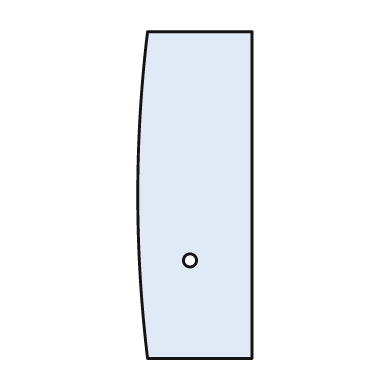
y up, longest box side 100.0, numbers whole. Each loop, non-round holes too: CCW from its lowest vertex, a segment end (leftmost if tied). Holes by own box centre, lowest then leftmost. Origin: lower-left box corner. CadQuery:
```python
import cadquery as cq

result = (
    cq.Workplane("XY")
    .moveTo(3.0, 0.0)
    .lineTo(35.0, 0.0)
    .lineTo(35.0, 100.0)
    .lineTo(3.0, 100.0)
    .threePointArc((0.0, 50.0), (3.0, 0.0))
    .close()
    .moveTo(16.0, 30.0)
    .circle(2.0)
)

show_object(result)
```